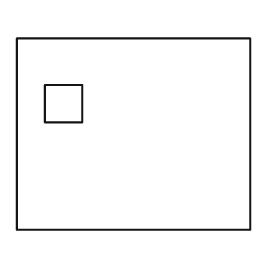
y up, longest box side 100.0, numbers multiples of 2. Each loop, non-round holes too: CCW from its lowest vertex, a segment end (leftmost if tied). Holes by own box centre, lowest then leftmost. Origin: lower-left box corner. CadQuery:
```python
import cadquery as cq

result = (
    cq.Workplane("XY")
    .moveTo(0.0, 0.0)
    .lineTo(100.0, 0.0)
    .lineTo(100.0, 82.0)
    .lineTo(0.0, 82.0)
    .close()
    .moveTo(12.0, 46.0)
    .lineTo(28.0, 46.0)
    .lineTo(28.0, 62.0)
    .lineTo(12.0, 62.0)
    .close()
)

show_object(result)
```